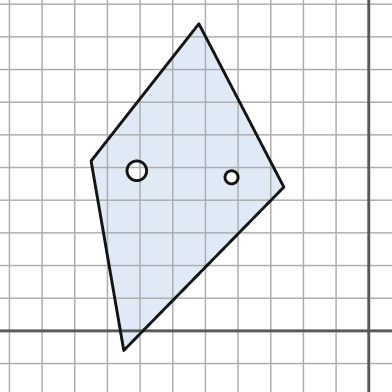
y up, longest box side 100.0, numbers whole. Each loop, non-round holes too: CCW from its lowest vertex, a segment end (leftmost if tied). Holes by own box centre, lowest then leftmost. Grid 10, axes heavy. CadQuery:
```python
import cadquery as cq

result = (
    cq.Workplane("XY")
    .moveTo(-75.0, -6.0)
    .lineTo(-26.0, 44.0)
    .lineTo(-52.0, 94.0)
    .lineTo(-85.0, 52.0)
    .close()
    .moveTo(-42.0, 47.0)
    .circle(2.0)
    .moveTo(-71.0, 49.0)
    .circle(3.0)
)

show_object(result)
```